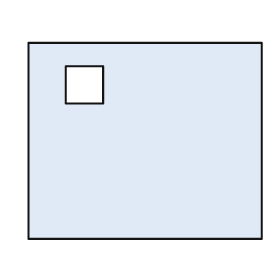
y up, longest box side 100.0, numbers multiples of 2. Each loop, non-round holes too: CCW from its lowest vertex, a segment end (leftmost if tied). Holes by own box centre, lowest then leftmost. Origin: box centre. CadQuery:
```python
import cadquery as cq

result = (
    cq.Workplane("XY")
    .moveTo(-50.0, -42.0)
    .lineTo(50.0, -42.0)
    .lineTo(50.0, 42.0)
    .lineTo(-50.0, 42.0)
    .close()
    .moveTo(-34.0, 16.0)
    .lineTo(-18.0, 16.0)
    .lineTo(-18.0, 32.0)
    .lineTo(-34.0, 32.0)
    .close()
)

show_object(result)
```